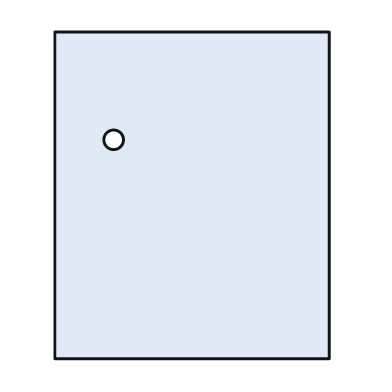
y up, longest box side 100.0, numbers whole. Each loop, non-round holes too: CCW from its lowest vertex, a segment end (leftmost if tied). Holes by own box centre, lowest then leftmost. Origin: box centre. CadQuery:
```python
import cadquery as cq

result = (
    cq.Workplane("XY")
    .moveTo(-42.0, -50.0)
    .lineTo(42.0, -50.0)
    .lineTo(42.0, 50.0)
    .lineTo(-42.0, 50.0)
    .close()
    .moveTo(-24.0, 17.0)
    .circle(3.0)
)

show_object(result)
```